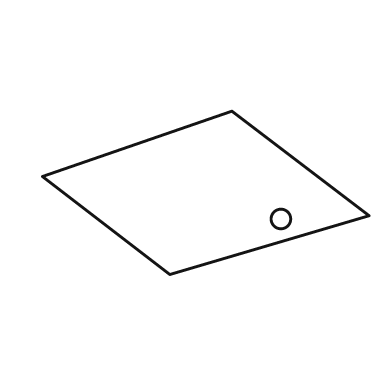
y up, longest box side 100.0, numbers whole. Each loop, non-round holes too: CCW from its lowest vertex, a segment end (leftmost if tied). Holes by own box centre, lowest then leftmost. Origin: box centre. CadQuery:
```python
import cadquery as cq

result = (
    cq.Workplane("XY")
    .moveTo(-11.0, -25.0)
    .lineTo(50.0, -7.0)
    .lineTo(8.0, 25.0)
    .lineTo(-50.0, 5.0)
    .close()
    .moveTo(23.0, -8.0)
    .circle(3.0)
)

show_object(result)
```